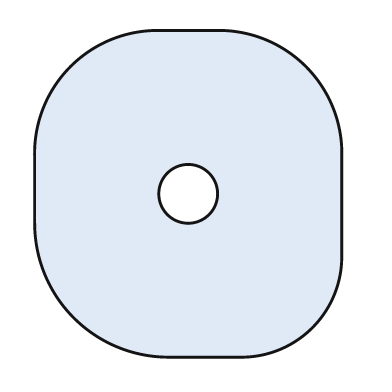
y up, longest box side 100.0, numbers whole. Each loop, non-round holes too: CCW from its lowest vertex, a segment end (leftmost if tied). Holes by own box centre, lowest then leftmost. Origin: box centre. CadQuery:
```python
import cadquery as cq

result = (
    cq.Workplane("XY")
    .moveTo(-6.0, -50.0)
    .lineTo(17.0, -50.0)
    .threePointArc((38.0, -41.0), (47.0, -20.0))
    .lineTo(47.0, 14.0)
    .threePointArc((36.0, 39.0), (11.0, 50.0))
    .lineTo(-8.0, 50.0)
    .threePointArc((-36.0, 39.0), (-47.0, 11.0))
    .lineTo(-47.0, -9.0)
    .threePointArc((-35.0, -38.0), (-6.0, -50.0))
    .close()
    .moveTo(0.0, 0.0)
    .circle(9.0)
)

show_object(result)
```